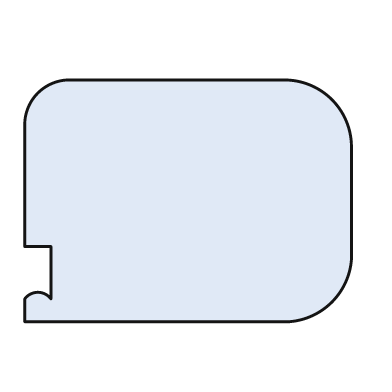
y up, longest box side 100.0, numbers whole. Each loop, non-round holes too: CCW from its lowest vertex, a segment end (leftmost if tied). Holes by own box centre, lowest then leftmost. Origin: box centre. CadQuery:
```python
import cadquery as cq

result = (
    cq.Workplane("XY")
    .moveTo(-50.0, -37.0)
    .lineTo(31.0, -37.0)
    .threePointArc((44.0, -31.0), (50.0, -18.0))
    .lineTo(50.0, 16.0)
    .threePointArc((44.0, 31.0), (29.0, 37.0))
    .lineTo(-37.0, 37.0)
    .threePointArc((-46.0, 33.0), (-50.0, 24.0))
    .lineTo(-50.0, -14.0)
    .lineTo(-42.0, -14.0)
    .lineTo(-42.0, -30.0)
    .threePointArc((-46.0, -28.0), (-50.0, -30.0))
    .close()
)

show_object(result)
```